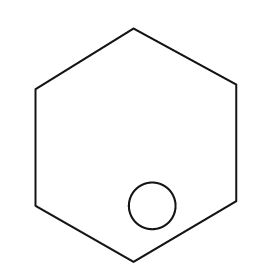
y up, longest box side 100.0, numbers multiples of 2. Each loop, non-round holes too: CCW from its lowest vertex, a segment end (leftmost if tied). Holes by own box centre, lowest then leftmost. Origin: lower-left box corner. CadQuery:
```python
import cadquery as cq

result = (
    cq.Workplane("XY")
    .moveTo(42.0, 0.0)
    .lineTo(86.0, 26.0)
    .lineTo(86.0, 76.0)
    .lineTo(42.0, 100.0)
    .lineTo(0.0, 74.0)
    .lineTo(0.0, 24.0)
    .close()
    .moveTo(50.0, 24.0)
    .circle(10.0)
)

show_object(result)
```